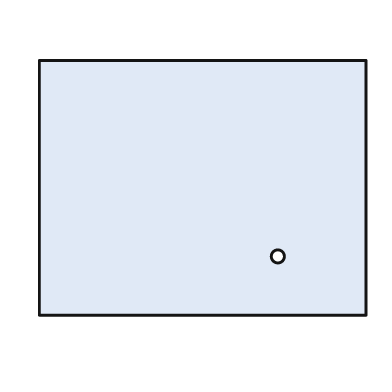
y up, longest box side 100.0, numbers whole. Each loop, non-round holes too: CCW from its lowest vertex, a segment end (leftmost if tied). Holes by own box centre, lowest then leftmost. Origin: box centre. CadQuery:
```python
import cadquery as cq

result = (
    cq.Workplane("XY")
    .moveTo(-50.0, -39.0)
    .lineTo(50.0, -39.0)
    .lineTo(50.0, 39.0)
    .lineTo(-50.0, 39.0)
    .close()
    .moveTo(23.0, -21.0)
    .circle(2.0)
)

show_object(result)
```